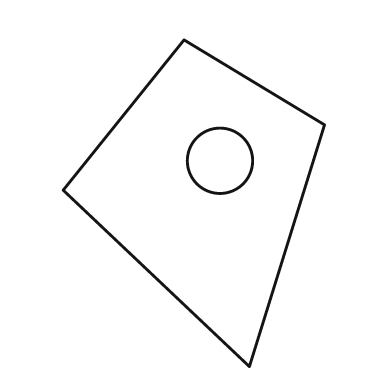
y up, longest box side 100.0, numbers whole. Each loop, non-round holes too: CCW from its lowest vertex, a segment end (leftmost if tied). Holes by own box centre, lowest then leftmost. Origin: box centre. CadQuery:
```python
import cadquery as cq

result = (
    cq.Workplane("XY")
    .moveTo(17.0, -50.0)
    .lineTo(40.0, 24.0)
    .lineTo(-3.0, 50.0)
    .lineTo(-40.0, 4.0)
    .close()
    .moveTo(8.0, 13.0)
    .circle(10.0)
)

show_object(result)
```